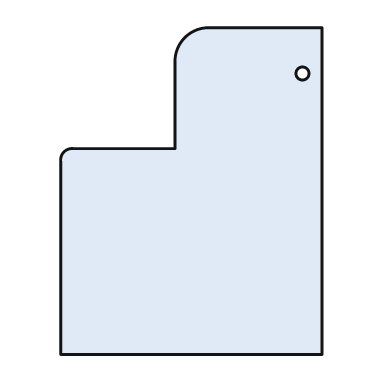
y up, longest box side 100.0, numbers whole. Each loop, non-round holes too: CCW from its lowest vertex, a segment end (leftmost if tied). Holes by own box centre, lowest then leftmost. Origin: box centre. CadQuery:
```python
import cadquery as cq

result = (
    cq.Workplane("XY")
    .moveTo(-40.0, -50.0)
    .lineTo(40.0, -50.0)
    .lineTo(40.0, 50.0)
    .lineTo(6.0, 50.0)
    .threePointArc((-2.0, 47.0), (-5.0, 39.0))
    .lineTo(-5.0, 13.0)
    .lineTo(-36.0, 13.0)
    .threePointArc((-39.0, 12.0), (-40.0, 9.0))
    .close()
    .moveTo(34.0, 36.0)
    .circle(2.0)
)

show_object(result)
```